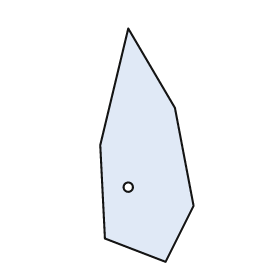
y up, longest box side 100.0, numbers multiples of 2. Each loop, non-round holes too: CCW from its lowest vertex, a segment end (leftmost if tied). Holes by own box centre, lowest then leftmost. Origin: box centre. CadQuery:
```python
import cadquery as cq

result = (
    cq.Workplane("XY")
    .moveTo(8.0, -50.0)
    .lineTo(20.0, -26.0)
    .lineTo(12.0, 16.0)
    .lineTo(-8.0, 50.0)
    .lineTo(-20.0, 0.0)
    .lineTo(-18.0, -40.0)
    .close()
    .moveTo(-8.0, -18.0)
    .circle(2.0)
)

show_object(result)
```